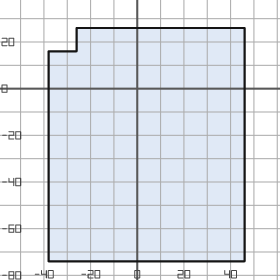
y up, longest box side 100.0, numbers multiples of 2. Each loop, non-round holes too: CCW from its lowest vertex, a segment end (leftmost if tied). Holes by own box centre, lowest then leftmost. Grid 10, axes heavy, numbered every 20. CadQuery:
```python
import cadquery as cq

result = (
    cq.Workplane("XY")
    .moveTo(-38.0, -74.0)
    .lineTo(46.0, -74.0)
    .lineTo(46.0, 26.0)
    .lineTo(-26.0, 26.0)
    .lineTo(-26.0, 16.0)
    .lineTo(-38.0, 16.0)
    .close()
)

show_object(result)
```